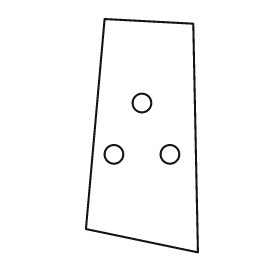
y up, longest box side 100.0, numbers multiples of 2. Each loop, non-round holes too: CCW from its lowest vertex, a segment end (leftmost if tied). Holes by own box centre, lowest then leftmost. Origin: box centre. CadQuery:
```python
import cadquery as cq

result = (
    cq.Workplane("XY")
    .moveTo(24.0, -50.0)
    .lineTo(22.0, 48.0)
    .lineTo(-16.0, 50.0)
    .lineTo(-24.0, -40.0)
    .close()
    .moveTo(-12.0, -8.0)
    .circle(4.0)
    .moveTo(12.0, -8.0)
    .circle(4.0)
    .moveTo(0.0, 14.0)
    .circle(4.0)
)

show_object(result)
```